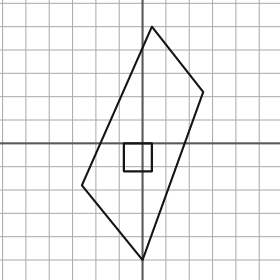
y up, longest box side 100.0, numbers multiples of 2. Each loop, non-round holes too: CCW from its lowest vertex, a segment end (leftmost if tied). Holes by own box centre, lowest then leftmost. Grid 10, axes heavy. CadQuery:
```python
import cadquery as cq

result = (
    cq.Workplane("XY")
    .moveTo(0.0, -50.0)
    .lineTo(26.0, 22.0)
    .lineTo(4.0, 50.0)
    .lineTo(-26.0, -18.0)
    .close()
    .moveTo(-8.0, -12.0)
    .lineTo(4.0, -12.0)
    .lineTo(4.0, 0.0)
    .lineTo(-8.0, 0.0)
    .close()
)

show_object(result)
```